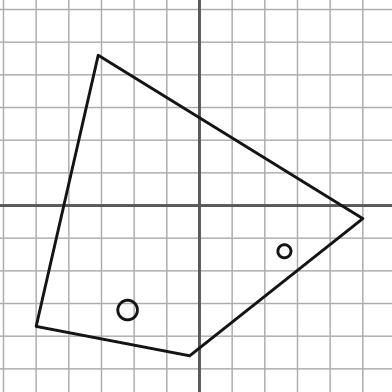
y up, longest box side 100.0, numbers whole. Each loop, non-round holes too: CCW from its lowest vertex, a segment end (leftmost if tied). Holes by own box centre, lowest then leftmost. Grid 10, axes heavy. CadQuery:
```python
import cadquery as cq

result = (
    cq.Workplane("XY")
    .moveTo(-3.0, -46.0)
    .lineTo(50.0, -4.0)
    .lineTo(-31.0, 46.0)
    .lineTo(-50.0, -37.0)
    .close()
    .moveTo(-22.0, -32.0)
    .circle(3.0)
    .moveTo(26.0, -14.0)
    .circle(2.0)
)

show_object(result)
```